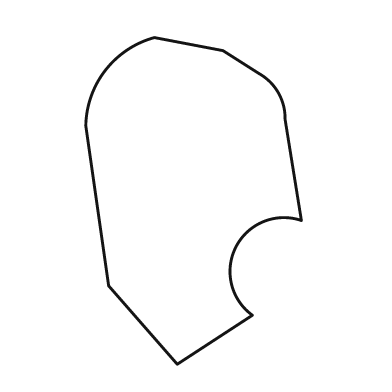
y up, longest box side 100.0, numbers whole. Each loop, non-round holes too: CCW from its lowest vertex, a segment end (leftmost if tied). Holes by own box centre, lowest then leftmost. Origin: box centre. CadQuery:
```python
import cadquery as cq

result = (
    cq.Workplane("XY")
    .moveTo(-5.0, -50.0)
    .lineTo(18.0, -35.0)
    .threePointArc((13.0, -14.0), (33.0, -6.0))
    .lineTo(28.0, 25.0)
    .threePointArc((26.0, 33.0), (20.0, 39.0))
    .lineTo(9.0, 46.0)
    .lineTo(-12.0, 50.0)
    .threePointArc((-27.0, 40.0), (-33.0, 23.0))
    .lineTo(-26.0, -26.0)
    .close()
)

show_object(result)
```